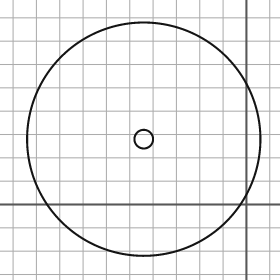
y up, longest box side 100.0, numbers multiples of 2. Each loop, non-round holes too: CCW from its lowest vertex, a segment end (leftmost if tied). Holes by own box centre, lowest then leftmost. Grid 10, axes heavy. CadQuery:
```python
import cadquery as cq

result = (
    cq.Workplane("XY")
    .moveTo(-44.0, 28.0)
    .circle(50.0)
    .moveTo(-44.0, 28.0)
    .circle(4.0)
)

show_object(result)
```